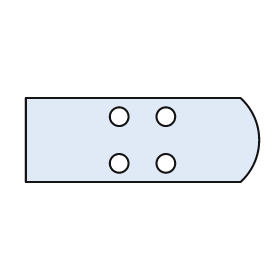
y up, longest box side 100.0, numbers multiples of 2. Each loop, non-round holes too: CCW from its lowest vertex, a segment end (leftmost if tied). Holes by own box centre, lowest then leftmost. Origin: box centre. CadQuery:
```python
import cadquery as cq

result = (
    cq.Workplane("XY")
    .moveTo(-50.0, -18.0)
    .lineTo(42.0, -18.0)
    .threePointArc((50.0, 0.0), (42.0, 18.0))
    .lineTo(-50.0, 18.0)
    .close()
    .moveTo(-10.0, -10.0)
    .circle(4.0)
    .moveTo(10.0, -10.0)
    .circle(4.0)
    .moveTo(-10.0, 10.0)
    .circle(4.0)
    .moveTo(10.0, 10.0)
    .circle(4.0)
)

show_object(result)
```